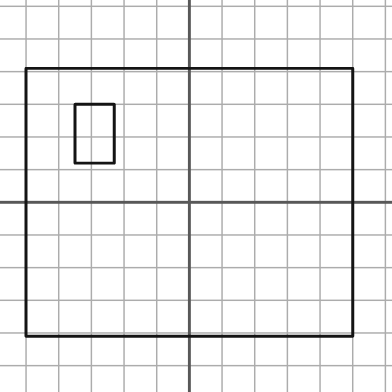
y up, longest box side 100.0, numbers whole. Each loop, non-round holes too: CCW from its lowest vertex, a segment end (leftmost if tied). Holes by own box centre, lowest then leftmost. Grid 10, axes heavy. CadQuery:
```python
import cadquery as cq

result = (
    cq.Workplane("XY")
    .moveTo(-50.0, -41.0)
    .lineTo(50.0, -41.0)
    .lineTo(50.0, 41.0)
    .lineTo(-50.0, 41.0)
    .close()
    .moveTo(-35.0, 12.0)
    .lineTo(-23.0, 12.0)
    .lineTo(-23.0, 30.0)
    .lineTo(-35.0, 30.0)
    .close()
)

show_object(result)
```